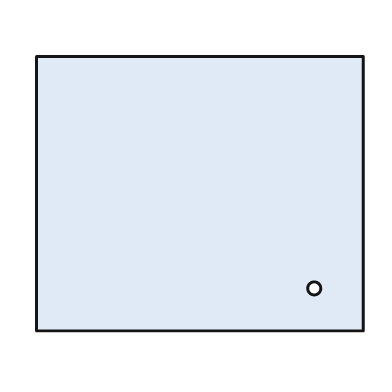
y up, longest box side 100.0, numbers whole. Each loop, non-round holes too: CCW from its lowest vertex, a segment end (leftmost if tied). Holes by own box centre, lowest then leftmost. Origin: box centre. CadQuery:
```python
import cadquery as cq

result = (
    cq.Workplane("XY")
    .moveTo(-50.0, -42.0)
    .lineTo(50.0, -42.0)
    .lineTo(50.0, 42.0)
    .lineTo(-50.0, 42.0)
    .close()
    .moveTo(35.0, -29.0)
    .circle(2.0)
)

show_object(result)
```